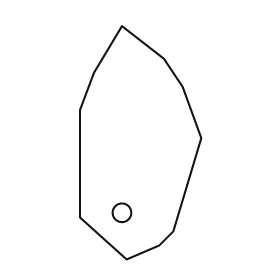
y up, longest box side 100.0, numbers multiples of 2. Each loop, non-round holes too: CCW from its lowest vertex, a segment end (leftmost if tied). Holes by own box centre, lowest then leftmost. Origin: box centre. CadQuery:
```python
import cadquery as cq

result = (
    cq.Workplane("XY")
    .moveTo(-6.0, -50.0)
    .lineTo(8.0, -44.0)
    .lineTo(14.0, -38.0)
    .lineTo(26.0, 2.0)
    .lineTo(18.0, 24.0)
    .lineTo(10.0, 36.0)
    .lineTo(-8.0, 50.0)
    .lineTo(-20.0, 30.0)
    .lineTo(-26.0, 14.0)
    .lineTo(-26.0, -32.0)
    .close()
    .moveTo(-8.0, -30.0)
    .circle(4.0)
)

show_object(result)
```